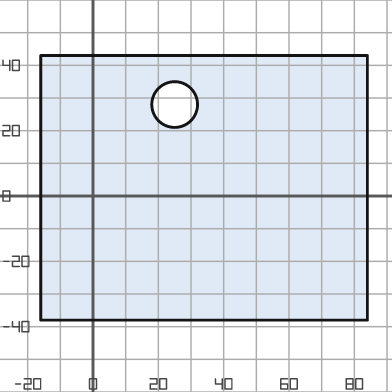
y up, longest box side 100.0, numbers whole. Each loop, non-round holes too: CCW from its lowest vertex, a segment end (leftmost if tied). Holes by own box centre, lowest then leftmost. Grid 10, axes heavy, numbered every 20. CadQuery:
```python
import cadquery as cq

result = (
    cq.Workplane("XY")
    .moveTo(-16.0, -38.0)
    .lineTo(84.0, -38.0)
    .lineTo(84.0, 43.0)
    .lineTo(-16.0, 43.0)
    .close()
    .moveTo(25.0, 28.0)
    .circle(7.0)
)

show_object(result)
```